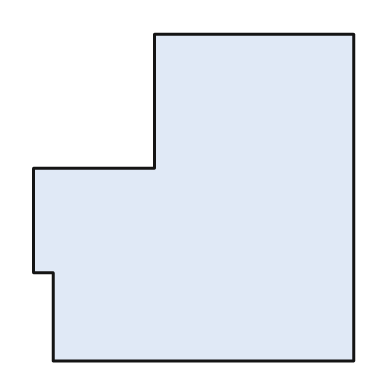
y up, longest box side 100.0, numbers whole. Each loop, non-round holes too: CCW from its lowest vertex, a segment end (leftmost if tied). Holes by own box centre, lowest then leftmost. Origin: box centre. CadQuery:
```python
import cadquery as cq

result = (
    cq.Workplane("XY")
    .moveTo(-43.0, -50.0)
    .lineTo(49.0, -50.0)
    .lineTo(49.0, 50.0)
    .lineTo(-12.0, 50.0)
    .lineTo(-12.0, 9.0)
    .lineTo(-49.0, 9.0)
    .lineTo(-49.0, -23.0)
    .lineTo(-43.0, -23.0)
    .close()
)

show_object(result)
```